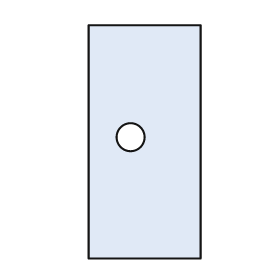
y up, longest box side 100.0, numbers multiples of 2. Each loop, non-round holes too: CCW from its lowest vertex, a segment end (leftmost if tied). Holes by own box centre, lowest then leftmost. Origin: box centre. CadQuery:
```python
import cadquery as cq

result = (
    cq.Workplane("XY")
    .moveTo(-24.0, -50.0)
    .lineTo(24.0, -50.0)
    .lineTo(24.0, 50.0)
    .lineTo(-24.0, 50.0)
    .close()
    .moveTo(-6.0, 2.0)
    .circle(6.0)
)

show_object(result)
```